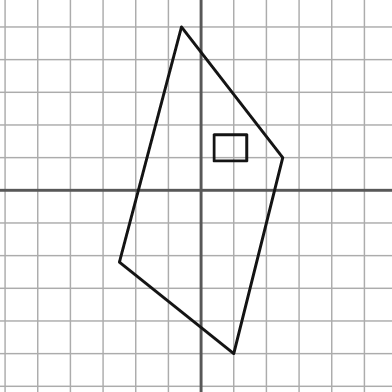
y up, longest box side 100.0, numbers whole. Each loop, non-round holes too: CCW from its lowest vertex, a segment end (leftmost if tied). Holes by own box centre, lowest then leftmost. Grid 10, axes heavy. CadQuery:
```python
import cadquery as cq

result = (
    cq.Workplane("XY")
    .moveTo(10.0, -50.0)
    .lineTo(25.0, 10.0)
    .lineTo(-6.0, 50.0)
    .lineTo(-25.0, -22.0)
    .close()
    .moveTo(4.0, 9.0)
    .lineTo(14.0, 9.0)
    .lineTo(14.0, 17.0)
    .lineTo(4.0, 17.0)
    .close()
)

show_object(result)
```